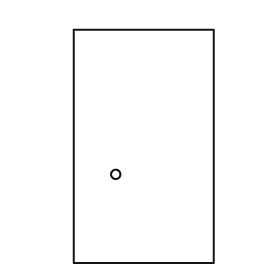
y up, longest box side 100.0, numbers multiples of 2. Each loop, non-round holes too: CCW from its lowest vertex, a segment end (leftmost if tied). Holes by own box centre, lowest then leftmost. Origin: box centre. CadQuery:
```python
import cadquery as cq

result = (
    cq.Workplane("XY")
    .moveTo(-30.0, -50.0)
    .lineTo(30.0, -50.0)
    .lineTo(30.0, 50.0)
    .lineTo(-30.0, 50.0)
    .close()
    .moveTo(-12.0, -12.0)
    .circle(2.0)
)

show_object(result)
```